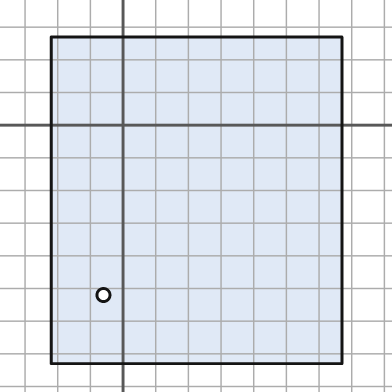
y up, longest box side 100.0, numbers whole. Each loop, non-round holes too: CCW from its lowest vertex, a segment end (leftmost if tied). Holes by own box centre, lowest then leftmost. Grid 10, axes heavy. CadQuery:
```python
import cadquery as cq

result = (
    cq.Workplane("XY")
    .moveTo(-22.0, -73.0)
    .lineTo(67.0, -73.0)
    .lineTo(67.0, 27.0)
    .lineTo(-22.0, 27.0)
    .close()
    .moveTo(-6.0, -52.0)
    .circle(2.0)
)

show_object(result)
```